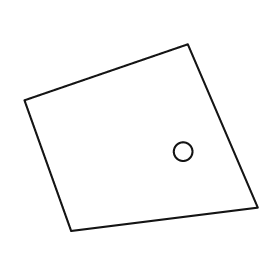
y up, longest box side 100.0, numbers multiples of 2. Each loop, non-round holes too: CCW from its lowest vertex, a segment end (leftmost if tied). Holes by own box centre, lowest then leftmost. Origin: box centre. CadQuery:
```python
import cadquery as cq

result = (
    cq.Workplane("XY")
    .moveTo(-30.0, -40.0)
    .lineTo(50.0, -30.0)
    .lineTo(20.0, 40.0)
    .lineTo(-50.0, 16.0)
    .close()
    .moveTo(18.0, -6.0)
    .circle(4.0)
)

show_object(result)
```